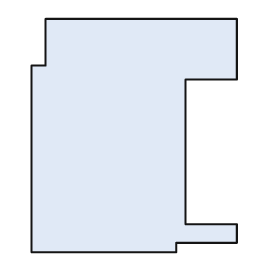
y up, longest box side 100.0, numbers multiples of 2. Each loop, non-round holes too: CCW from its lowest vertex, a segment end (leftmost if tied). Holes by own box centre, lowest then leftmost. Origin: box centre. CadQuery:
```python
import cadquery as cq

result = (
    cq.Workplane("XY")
    .moveTo(-44.0, -50.0)
    .lineTo(18.0, -50.0)
    .lineTo(18.0, -46.0)
    .lineTo(44.0, -46.0)
    .lineTo(44.0, -38.0)
    .lineTo(22.0, -38.0)
    .lineTo(22.0, 24.0)
    .lineTo(44.0, 24.0)
    .lineTo(44.0, 50.0)
    .lineTo(-38.0, 50.0)
    .lineTo(-38.0, 30.0)
    .lineTo(-44.0, 30.0)
    .close()
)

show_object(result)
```